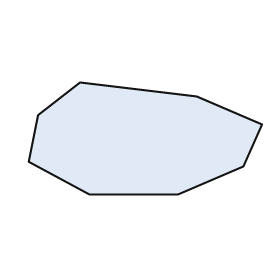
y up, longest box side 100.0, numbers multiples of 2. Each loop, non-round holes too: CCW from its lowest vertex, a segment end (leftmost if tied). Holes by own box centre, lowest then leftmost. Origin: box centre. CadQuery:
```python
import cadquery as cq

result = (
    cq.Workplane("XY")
    .moveTo(-24.0, -24.0)
    .lineTo(14.0, -24.0)
    .lineTo(42.0, -12.0)
    .lineTo(50.0, 6.0)
    .lineTo(22.0, 18.0)
    .lineTo(-28.0, 24.0)
    .lineTo(-46.0, 10.0)
    .lineTo(-50.0, -10.0)
    .close()
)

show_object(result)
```